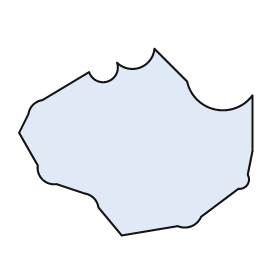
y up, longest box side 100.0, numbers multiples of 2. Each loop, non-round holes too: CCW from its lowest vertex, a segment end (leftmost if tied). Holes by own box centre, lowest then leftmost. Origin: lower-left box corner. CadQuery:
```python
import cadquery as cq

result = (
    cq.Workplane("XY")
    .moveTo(44.0, 0.0)
    .lineTo(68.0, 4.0)
    .threePointArc((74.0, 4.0), (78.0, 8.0))
    .lineTo(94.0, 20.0)
    .threePointArc((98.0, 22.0), (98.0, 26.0))
    .lineTo(100.0, 36.0)
    .lineTo(100.0, 60.0)
    .threePointArc((84.0, 54.0), (72.0, 66.0))
    .lineTo(58.0, 80.0)
    .threePointArc((52.0, 72.0), (42.0, 74.0))
    .threePointArc((38.0, 66.0), (30.0, 70.0))
    .lineTo(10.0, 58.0)
    .threePointArc((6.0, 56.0), (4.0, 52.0))
    .lineTo(0.0, 44.0)
    .lineTo(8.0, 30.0)
    .threePointArc((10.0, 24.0), (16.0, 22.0))
    .lineTo(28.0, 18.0)
    .threePointArc((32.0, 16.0), (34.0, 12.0))
    .close()
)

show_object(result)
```